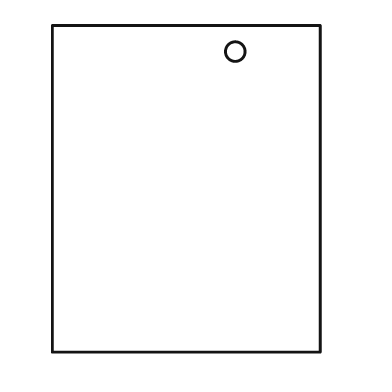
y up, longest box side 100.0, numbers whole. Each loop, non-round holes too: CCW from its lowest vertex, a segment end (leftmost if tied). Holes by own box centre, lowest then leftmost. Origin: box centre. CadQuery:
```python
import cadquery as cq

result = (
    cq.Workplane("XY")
    .moveTo(-41.0, -50.0)
    .lineTo(41.0, -50.0)
    .lineTo(41.0, 50.0)
    .lineTo(-41.0, 50.0)
    .close()
    .moveTo(15.0, 42.0)
    .circle(3.0)
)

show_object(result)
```